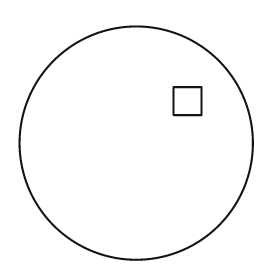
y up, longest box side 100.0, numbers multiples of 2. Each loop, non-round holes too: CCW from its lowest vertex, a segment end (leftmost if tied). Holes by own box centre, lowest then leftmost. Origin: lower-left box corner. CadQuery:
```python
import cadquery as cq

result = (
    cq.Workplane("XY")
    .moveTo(50.0, 50.0)
    .circle(50.0)
    .moveTo(66.0, 62.0)
    .lineTo(78.0, 62.0)
    .lineTo(78.0, 74.0)
    .lineTo(66.0, 74.0)
    .close()
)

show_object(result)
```